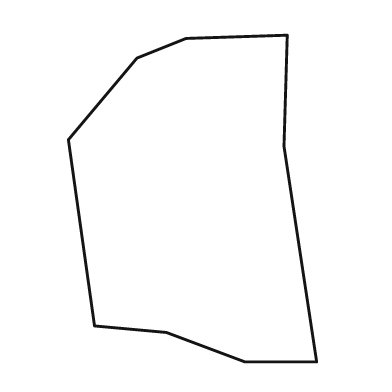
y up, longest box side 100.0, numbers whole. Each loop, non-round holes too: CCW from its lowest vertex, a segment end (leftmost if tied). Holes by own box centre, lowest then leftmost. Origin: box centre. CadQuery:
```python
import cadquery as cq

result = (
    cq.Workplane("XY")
    .moveTo(16.0, -50.0)
    .lineTo(38.0, -50.0)
    .lineTo(28.0, 16.0)
    .lineTo(29.0, 50.0)
    .lineTo(-2.0, 49.0)
    .lineTo(-17.0, 43.0)
    .lineTo(-38.0, 18.0)
    .lineTo(-30.0, -39.0)
    .lineTo(-8.0, -41.0)
    .close()
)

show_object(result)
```